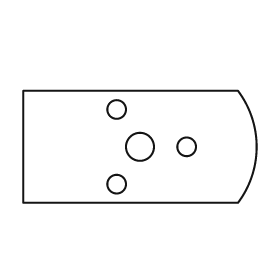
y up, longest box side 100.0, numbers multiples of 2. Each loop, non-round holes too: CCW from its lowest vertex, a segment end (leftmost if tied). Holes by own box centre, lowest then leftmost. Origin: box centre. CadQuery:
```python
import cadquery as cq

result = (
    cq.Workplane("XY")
    .moveTo(-50.0, -24.0)
    .lineTo(42.0, -24.0)
    .threePointArc((50.0, 0.0), (42.0, 24.0))
    .lineTo(-50.0, 24.0)
    .close()
    .moveTo(-10.0, -16.0)
    .circle(4.0)
    .moveTo(0.0, 0.0)
    .circle(6.0)
    .moveTo(20.0, 0.0)
    .circle(4.0)
    .moveTo(-10.0, 16.0)
    .circle(4.0)
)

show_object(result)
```